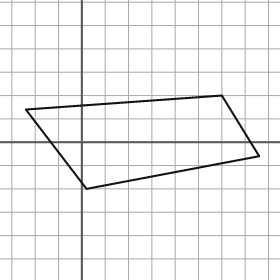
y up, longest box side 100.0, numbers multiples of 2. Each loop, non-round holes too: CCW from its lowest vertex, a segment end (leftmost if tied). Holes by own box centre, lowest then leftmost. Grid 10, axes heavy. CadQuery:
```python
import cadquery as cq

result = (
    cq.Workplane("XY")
    .moveTo(2.0, -20.0)
    .lineTo(76.0, -6.0)
    .lineTo(60.0, 20.0)
    .lineTo(-24.0, 14.0)
    .close()
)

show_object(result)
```